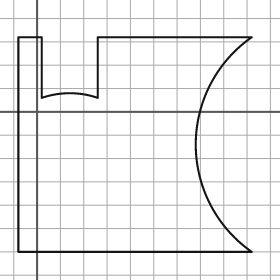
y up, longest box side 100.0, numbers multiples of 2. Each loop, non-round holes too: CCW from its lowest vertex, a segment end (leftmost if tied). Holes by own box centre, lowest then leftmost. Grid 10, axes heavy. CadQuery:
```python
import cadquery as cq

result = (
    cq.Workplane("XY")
    .moveTo(-8.0, -60.0)
    .lineTo(92.0, -60.0)
    .threePointArc((68.0, -14.0), (92.0, 32.0))
    .lineTo(26.0, 32.0)
    .lineTo(26.0, 6.0)
    .threePointArc((14.0, 8.0), (2.0, 6.0))
    .lineTo(2.0, 32.0)
    .lineTo(-8.0, 32.0)
    .close()
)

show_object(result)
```